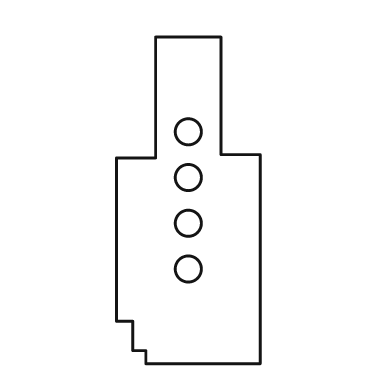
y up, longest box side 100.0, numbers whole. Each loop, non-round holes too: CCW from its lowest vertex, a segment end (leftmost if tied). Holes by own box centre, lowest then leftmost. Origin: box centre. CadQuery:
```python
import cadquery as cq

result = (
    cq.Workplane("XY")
    .moveTo(-13.0, -50.0)
    .lineTo(22.0, -50.0)
    .lineTo(22.0, 14.0)
    .lineTo(10.0, 14.0)
    .lineTo(10.0, 50.0)
    .lineTo(-10.0, 50.0)
    .lineTo(-10.0, 13.0)
    .lineTo(-22.0, 13.0)
    .lineTo(-22.0, -37.0)
    .lineTo(-17.0, -37.0)
    .lineTo(-17.0, -46.0)
    .lineTo(-13.0, -46.0)
    .close()
    .moveTo(0.0, -21.0)
    .circle(4.0)
    .moveTo(0.0, -7.0)
    .circle(4.0)
    .moveTo(0.0, 7.0)
    .circle(4.0)
    .moveTo(0.0, 21.0)
    .circle(4.0)
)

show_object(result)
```